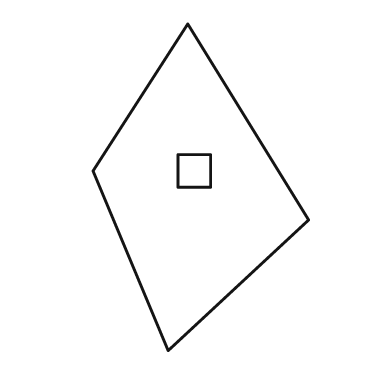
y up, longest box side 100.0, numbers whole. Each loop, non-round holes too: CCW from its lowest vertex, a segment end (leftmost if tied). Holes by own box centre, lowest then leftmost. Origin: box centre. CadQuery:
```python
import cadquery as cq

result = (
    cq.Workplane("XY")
    .moveTo(-10.0, -50.0)
    .lineTo(33.0, -10.0)
    .lineTo(-4.0, 50.0)
    .lineTo(-33.0, 5.0)
    .close()
    .moveTo(-7.0, 0.0)
    .lineTo(3.0, 0.0)
    .lineTo(3.0, 10.0)
    .lineTo(-7.0, 10.0)
    .close()
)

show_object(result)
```